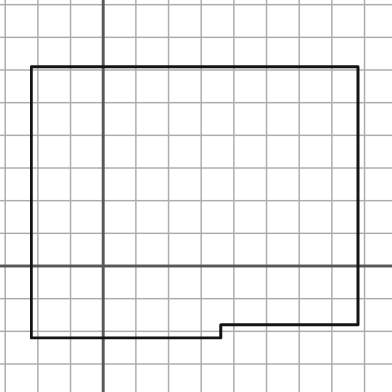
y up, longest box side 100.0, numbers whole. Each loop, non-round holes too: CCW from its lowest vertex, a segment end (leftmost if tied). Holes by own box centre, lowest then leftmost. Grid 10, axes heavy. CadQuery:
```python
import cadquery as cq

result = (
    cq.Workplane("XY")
    .moveTo(-22.0, -22.0)
    .lineTo(36.0, -22.0)
    .lineTo(36.0, -18.0)
    .lineTo(78.0, -18.0)
    .lineTo(78.0, 61.0)
    .lineTo(-22.0, 61.0)
    .close()
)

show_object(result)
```